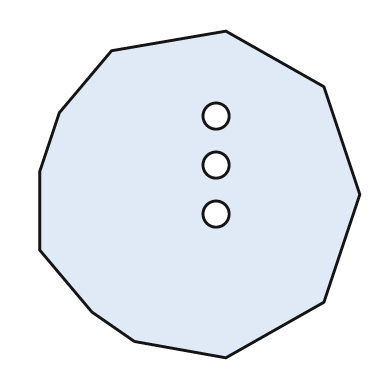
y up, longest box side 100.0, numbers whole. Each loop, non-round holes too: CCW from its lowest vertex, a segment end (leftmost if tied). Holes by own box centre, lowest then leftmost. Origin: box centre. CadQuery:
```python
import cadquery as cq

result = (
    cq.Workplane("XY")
    .moveTo(8.0, -50.0)
    .lineTo(38.0, -33.0)
    .lineTo(49.0, 0.0)
    .lineTo(38.0, 33.0)
    .lineTo(8.0, 50.0)
    .lineTo(-27.0, 44.0)
    .lineTo(-43.0, 25.0)
    .lineTo(-49.0, 7.0)
    .lineTo(-49.0, -17.0)
    .lineTo(-33.0, -36.0)
    .lineTo(-20.0, -45.0)
    .close()
    .moveTo(5.0, -6.0)
    .circle(4.0)
    .moveTo(5.0, 9.0)
    .circle(4.0)
    .moveTo(5.0, 24.0)
    .circle(4.0)
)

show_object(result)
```